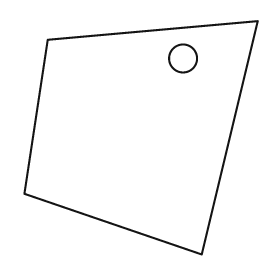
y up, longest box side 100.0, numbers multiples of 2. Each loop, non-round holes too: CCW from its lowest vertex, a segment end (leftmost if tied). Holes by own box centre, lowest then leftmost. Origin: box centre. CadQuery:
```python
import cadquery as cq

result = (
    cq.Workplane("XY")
    .moveTo(26.0, -50.0)
    .lineTo(50.0, 50.0)
    .lineTo(-40.0, 42.0)
    .lineTo(-50.0, -24.0)
    .close()
    .moveTo(18.0, 34.0)
    .circle(6.0)
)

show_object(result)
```